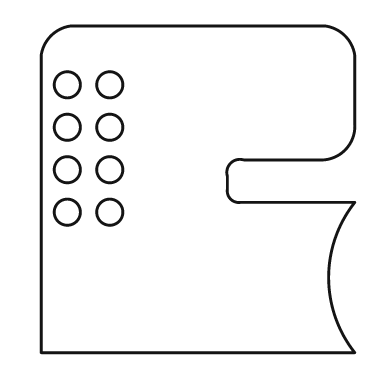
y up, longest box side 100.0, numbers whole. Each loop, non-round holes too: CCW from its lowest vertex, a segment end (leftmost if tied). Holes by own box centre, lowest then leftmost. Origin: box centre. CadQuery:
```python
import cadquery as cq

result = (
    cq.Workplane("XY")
    .moveTo(-48.0, -50.0)
    .lineTo(48.0, -50.0)
    .threePointArc((40.0, -27.0), (48.0, -4.0))
    .lineTo(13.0, -4.0)
    .threePointArc((10.0, -3.0), (9.0, 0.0))
    .lineTo(9.0, 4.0)
    .threePointArc((10.0, 8.0), (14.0, 9.0))
    .lineTo(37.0, 9.0)
    .threePointArc((45.0, 12.0), (48.0, 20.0))
    .lineTo(48.0, 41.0)
    .threePointArc((45.0, 47.0), (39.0, 50.0))
    .lineTo(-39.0, 50.0)
    .threePointArc((-45.0, 47.0), (-48.0, 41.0))
    .close()
    .moveTo(-40.0, -7.0)
    .circle(4.0)
    .moveTo(-27.0, -7.0)
    .circle(4.0)
    .moveTo(-40.0, 6.0)
    .circle(4.0)
    .moveTo(-27.0, 6.0)
    .circle(4.0)
    .moveTo(-40.0, 19.0)
    .circle(4.0)
    .moveTo(-27.0, 19.0)
    .circle(4.0)
    .moveTo(-40.0, 32.0)
    .circle(4.0)
    .moveTo(-27.0, 32.0)
    .circle(4.0)
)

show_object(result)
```